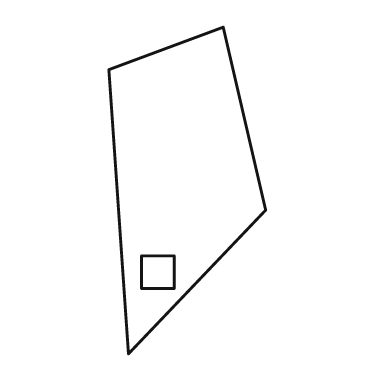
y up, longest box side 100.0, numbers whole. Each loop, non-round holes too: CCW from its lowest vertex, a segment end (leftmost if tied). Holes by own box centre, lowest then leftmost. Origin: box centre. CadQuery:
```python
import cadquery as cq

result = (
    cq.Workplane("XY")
    .moveTo(-18.0, -50.0)
    .lineTo(24.0, -6.0)
    .lineTo(11.0, 50.0)
    .lineTo(-24.0, 37.0)
    .close()
    .moveTo(-14.0, -30.0)
    .lineTo(-4.0, -30.0)
    .lineTo(-4.0, -20.0)
    .lineTo(-14.0, -20.0)
    .close()
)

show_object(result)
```